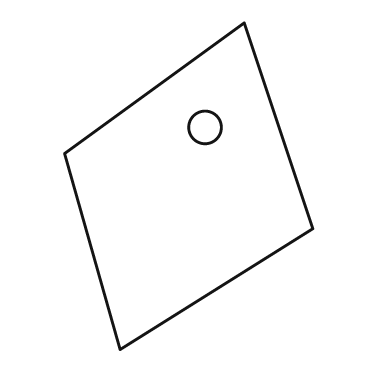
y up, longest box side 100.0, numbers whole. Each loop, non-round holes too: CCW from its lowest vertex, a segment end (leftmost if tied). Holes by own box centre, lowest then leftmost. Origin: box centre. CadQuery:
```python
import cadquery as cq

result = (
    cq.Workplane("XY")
    .moveTo(-21.0, -50.0)
    .lineTo(38.0, -13.0)
    .lineTo(17.0, 50.0)
    .lineTo(-38.0, 10.0)
    .close()
    .moveTo(5.0, 18.0)
    .circle(5.0)
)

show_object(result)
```